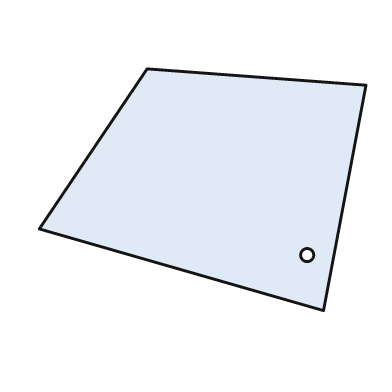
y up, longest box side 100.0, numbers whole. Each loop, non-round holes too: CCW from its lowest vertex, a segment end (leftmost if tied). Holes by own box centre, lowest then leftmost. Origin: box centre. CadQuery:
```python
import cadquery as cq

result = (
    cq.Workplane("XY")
    .moveTo(37.0, -37.0)
    .lineTo(50.0, 32.0)
    .lineTo(-17.0, 37.0)
    .lineTo(-50.0, -12.0)
    .close()
    .moveTo(32.0, -20.0)
    .circle(2.0)
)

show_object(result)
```